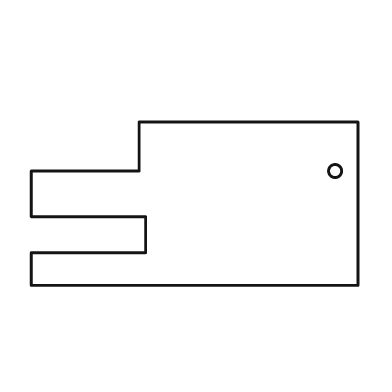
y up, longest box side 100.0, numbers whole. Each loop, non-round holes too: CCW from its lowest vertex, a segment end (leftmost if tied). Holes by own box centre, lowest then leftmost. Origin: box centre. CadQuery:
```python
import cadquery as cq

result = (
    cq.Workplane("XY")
    .moveTo(-50.0, -25.0)
    .lineTo(50.0, -25.0)
    .lineTo(50.0, 25.0)
    .lineTo(-17.0, 25.0)
    .lineTo(-17.0, 10.0)
    .lineTo(-50.0, 10.0)
    .lineTo(-50.0, -4.0)
    .lineTo(-15.0, -4.0)
    .lineTo(-15.0, -15.0)
    .lineTo(-50.0, -15.0)
    .close()
    .moveTo(43.0, 10.0)
    .circle(2.0)
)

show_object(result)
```